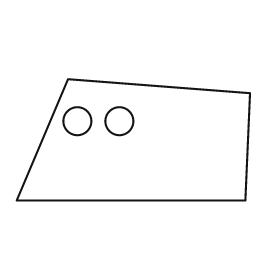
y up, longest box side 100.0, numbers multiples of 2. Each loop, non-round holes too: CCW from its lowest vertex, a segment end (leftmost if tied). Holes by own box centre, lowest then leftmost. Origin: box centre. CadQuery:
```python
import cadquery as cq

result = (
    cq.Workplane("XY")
    .moveTo(-50.0, -26.0)
    .lineTo(48.0, -26.0)
    .lineTo(50.0, 20.0)
    .lineTo(-28.0, 26.0)
    .close()
    .moveTo(-24.0, 8.0)
    .circle(6.0)
    .moveTo(-6.0, 8.0)
    .circle(6.0)
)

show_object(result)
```